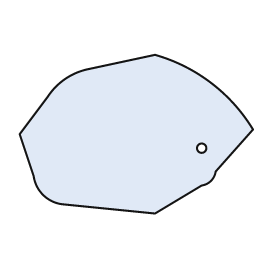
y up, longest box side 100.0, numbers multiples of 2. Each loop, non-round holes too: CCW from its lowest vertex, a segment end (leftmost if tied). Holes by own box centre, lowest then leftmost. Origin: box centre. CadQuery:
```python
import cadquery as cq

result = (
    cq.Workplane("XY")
    .moveTo(8.0, -34.0)
    .lineTo(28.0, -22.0)
    .threePointArc((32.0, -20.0), (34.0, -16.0))
    .lineTo(50.0, 2.0)
    .threePointArc((32.0, 22.0), (8.0, 34.0))
    .lineTo(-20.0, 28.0)
    .threePointArc((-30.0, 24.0), (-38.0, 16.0))
    .lineTo(-50.0, 0.0)
    .lineTo(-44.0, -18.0)
    .threePointArc((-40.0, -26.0), (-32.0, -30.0))
    .close()
    .moveTo(28.0, -6.0)
    .circle(2.0)
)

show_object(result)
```